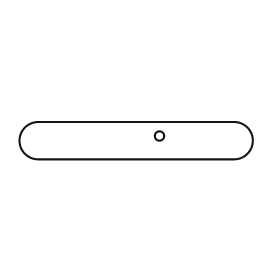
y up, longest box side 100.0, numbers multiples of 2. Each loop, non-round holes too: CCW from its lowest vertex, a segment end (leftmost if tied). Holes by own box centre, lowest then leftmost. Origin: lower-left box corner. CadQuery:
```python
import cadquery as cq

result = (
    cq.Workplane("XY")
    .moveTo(8.0, 0.0)
    .lineTo(92.0, 0.0)
    .threePointArc((100.0, 8.0), (92.0, 16.0))
    .lineTo(8.0, 16.0)
    .threePointArc((0.0, 8.0), (8.0, 0.0))
    .close()
    .moveTo(60.0, 10.0)
    .circle(2.0)
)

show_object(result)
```